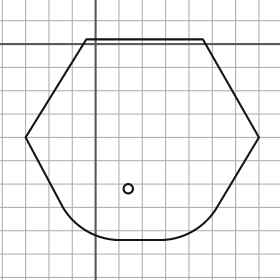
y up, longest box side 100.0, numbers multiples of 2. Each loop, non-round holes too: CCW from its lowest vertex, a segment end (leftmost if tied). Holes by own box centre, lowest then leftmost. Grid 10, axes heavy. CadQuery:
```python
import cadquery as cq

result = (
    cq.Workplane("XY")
    .moveTo(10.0, -84.0)
    .lineTo(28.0, -84.0)
    .threePointArc((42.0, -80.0), (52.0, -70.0))
    .lineTo(70.0, -40.0)
    .lineTo(46.0, 2.0)
    .lineTo(-4.0, 2.0)
    .lineTo(-30.0, -40.0)
    .lineTo(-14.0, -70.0)
    .threePointArc((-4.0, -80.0), (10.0, -84.0))
    .close()
    .moveTo(14.0, -62.0)
    .circle(2.0)
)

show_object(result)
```